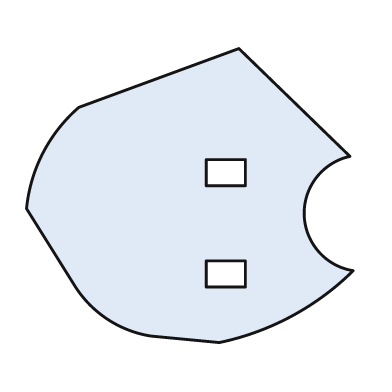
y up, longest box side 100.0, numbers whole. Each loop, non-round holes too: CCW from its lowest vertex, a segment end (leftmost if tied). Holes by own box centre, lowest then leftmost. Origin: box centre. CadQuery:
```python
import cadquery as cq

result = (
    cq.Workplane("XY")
    .moveTo(9.0, -45.0)
    .threePointArc((31.0, -37.0), (50.0, -23.0))
    .threePointArc((35.0, -6.0), (49.0, 12.0))
    .lineTo(15.0, 45.0)
    .lineTo(-34.0, 27.0)
    .threePointArc((-45.0, 13.0), (-50.0, -4.0))
    .lineTo(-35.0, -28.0)
    .threePointArc((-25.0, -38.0), (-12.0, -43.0))
    .close()
    .moveTo(5.0, -28.0)
    .lineTo(17.0, -28.0)
    .lineTo(17.0, -20.0)
    .lineTo(5.0, -20.0)
    .close()
    .moveTo(5.0, 3.0)
    .lineTo(17.0, 3.0)
    .lineTo(17.0, 11.0)
    .lineTo(5.0, 11.0)
    .close()
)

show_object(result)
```